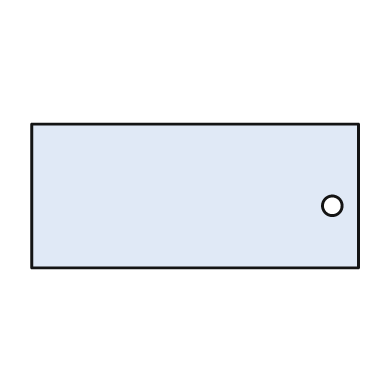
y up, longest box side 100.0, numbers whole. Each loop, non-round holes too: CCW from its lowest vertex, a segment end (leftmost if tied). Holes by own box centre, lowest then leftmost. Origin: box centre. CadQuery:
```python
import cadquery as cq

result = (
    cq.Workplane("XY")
    .moveTo(-50.0, -22.0)
    .lineTo(50.0, -22.0)
    .lineTo(50.0, 22.0)
    .lineTo(-50.0, 22.0)
    .close()
    .moveTo(42.0, -3.0)
    .circle(3.0)
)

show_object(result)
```